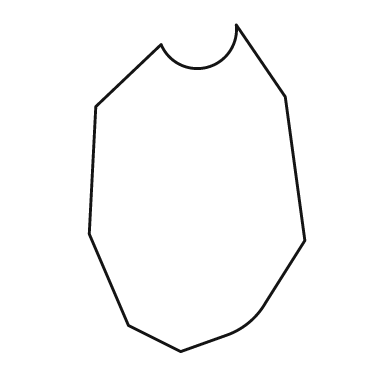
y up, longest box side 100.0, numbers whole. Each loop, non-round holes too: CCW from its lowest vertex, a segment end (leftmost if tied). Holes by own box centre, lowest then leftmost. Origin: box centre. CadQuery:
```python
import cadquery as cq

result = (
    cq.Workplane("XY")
    .moveTo(-5.0, -50.0)
    .lineTo(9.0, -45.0)
    .threePointArc((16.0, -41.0), (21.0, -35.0))
    .lineTo(33.0, -16.0)
    .lineTo(27.0, 28.0)
    .lineTo(12.0, 50.0)
    .threePointArc((3.0, 37.0), (-11.0, 44.0))
    .lineTo(-31.0, 25.0)
    .lineTo(-33.0, -14.0)
    .lineTo(-21.0, -42.0)
    .close()
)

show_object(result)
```